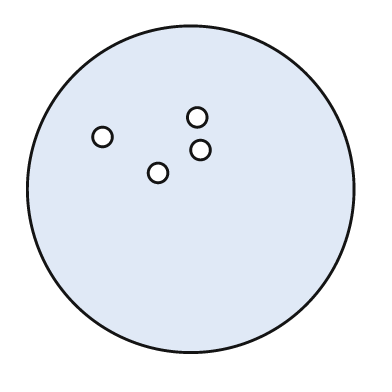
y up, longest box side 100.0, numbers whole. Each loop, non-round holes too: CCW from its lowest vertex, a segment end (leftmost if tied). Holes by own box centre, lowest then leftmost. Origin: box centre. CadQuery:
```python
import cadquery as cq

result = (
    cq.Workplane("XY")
    .moveTo(0.0, 0.0)
    .circle(50.0)
    .moveTo(-10.0, 5.0)
    .circle(3.0)
    .moveTo(3.0, 12.0)
    .circle(3.0)
    .moveTo(-27.0, 16.0)
    .circle(3.0)
    .moveTo(2.0, 22.0)
    .circle(3.0)
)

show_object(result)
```